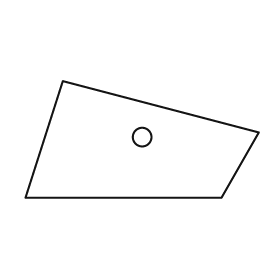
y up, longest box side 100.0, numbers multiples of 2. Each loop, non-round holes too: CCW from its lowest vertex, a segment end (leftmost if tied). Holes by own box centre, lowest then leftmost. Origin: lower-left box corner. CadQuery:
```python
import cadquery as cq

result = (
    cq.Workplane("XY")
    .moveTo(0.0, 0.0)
    .lineTo(84.0, 0.0)
    .lineTo(100.0, 28.0)
    .lineTo(16.0, 50.0)
    .close()
    .moveTo(50.0, 26.0)
    .circle(4.0)
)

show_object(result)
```